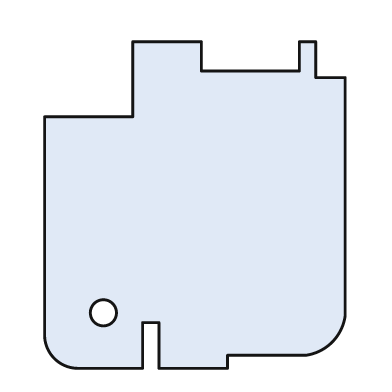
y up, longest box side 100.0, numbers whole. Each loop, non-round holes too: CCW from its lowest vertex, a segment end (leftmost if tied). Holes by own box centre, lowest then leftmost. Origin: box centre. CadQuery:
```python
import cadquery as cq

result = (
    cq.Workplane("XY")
    .moveTo(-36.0, -50.0)
    .lineTo(-16.0, -50.0)
    .lineTo(-16.0, -36.0)
    .lineTo(-11.0, -36.0)
    .lineTo(-11.0, -50.0)
    .lineTo(10.0, -50.0)
    .lineTo(10.0, -46.0)
    .lineTo(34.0, -46.0)
    .threePointArc((42.0, -42.0), (46.0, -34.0))
    .lineTo(46.0, 39.0)
    .lineTo(37.0, 39.0)
    .lineTo(37.0, 50.0)
    .lineTo(32.0, 50.0)
    .lineTo(32.0, 41.0)
    .lineTo(2.0, 41.0)
    .lineTo(2.0, 50.0)
    .lineTo(-19.0, 50.0)
    .lineTo(-19.0, 27.0)
    .lineTo(-46.0, 27.0)
    .lineTo(-46.0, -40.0)
    .threePointArc((-43.0, -47.0), (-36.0, -50.0))
    .close()
    .moveTo(-28.0, -33.0)
    .circle(4.0)
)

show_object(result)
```